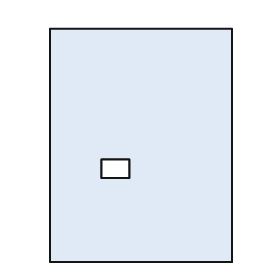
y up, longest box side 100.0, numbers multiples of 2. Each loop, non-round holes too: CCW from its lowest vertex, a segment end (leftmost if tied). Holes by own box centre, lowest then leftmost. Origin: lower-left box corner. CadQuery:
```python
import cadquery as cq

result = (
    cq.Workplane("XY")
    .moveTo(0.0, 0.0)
    .lineTo(78.0, 0.0)
    .lineTo(78.0, 100.0)
    .lineTo(0.0, 100.0)
    .close()
    .moveTo(22.0, 36.0)
    .lineTo(34.0, 36.0)
    .lineTo(34.0, 44.0)
    .lineTo(22.0, 44.0)
    .close()
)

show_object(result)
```